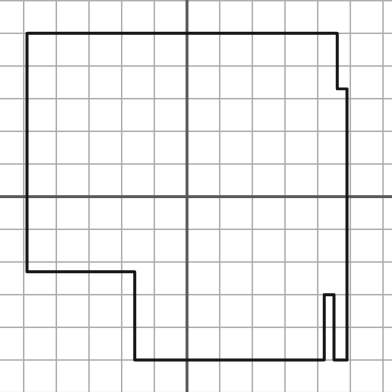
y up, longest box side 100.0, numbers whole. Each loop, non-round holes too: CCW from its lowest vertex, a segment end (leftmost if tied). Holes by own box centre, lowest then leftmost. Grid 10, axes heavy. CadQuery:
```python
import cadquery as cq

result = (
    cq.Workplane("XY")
    .moveTo(-16.0, -50.0)
    .lineTo(42.0, -50.0)
    .lineTo(42.0, -30.0)
    .lineTo(45.0, -30.0)
    .lineTo(45.0, -50.0)
    .lineTo(49.0, -50.0)
    .lineTo(49.0, 33.0)
    .lineTo(46.0, 33.0)
    .lineTo(46.0, 50.0)
    .lineTo(-49.0, 50.0)
    .lineTo(-49.0, -23.0)
    .lineTo(-16.0, -23.0)
    .close()
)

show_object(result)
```